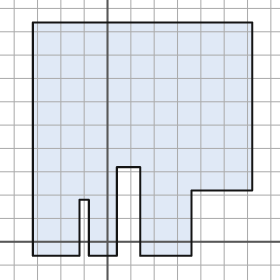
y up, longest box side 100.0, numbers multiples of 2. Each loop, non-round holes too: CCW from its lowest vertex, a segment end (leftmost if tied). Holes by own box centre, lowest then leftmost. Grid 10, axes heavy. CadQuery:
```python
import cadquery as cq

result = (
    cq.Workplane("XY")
    .moveTo(-32.0, -6.0)
    .lineTo(-12.0, -6.0)
    .lineTo(-12.0, 18.0)
    .lineTo(-8.0, 18.0)
    .lineTo(-8.0, -6.0)
    .lineTo(4.0, -6.0)
    .lineTo(4.0, 32.0)
    .lineTo(14.0, 32.0)
    .lineTo(14.0, -6.0)
    .lineTo(36.0, -6.0)
    .lineTo(36.0, 22.0)
    .lineTo(62.0, 22.0)
    .lineTo(62.0, 94.0)
    .lineTo(-32.0, 94.0)
    .close()
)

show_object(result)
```